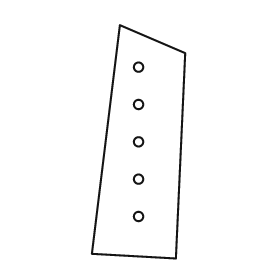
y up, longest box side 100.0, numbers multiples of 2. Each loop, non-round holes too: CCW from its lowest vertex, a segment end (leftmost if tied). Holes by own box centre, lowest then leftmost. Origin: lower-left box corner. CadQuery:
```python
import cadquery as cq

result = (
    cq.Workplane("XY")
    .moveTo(36.0, 0.0)
    .lineTo(40.0, 88.0)
    .lineTo(12.0, 100.0)
    .lineTo(0.0, 2.0)
    .close()
    .moveTo(20.0, 18.0)
    .circle(2.0)
    .moveTo(20.0, 34.0)
    .circle(2.0)
    .moveTo(20.0, 50.0)
    .circle(2.0)
    .moveTo(20.0, 66.0)
    .circle(2.0)
    .moveTo(20.0, 82.0)
    .circle(2.0)
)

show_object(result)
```